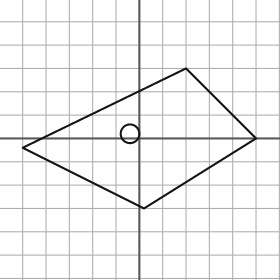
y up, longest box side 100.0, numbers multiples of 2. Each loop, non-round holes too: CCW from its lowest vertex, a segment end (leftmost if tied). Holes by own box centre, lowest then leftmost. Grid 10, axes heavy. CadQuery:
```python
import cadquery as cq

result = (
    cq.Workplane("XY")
    .moveTo(2.0, -30.0)
    .lineTo(50.0, 0.0)
    .lineTo(20.0, 30.0)
    .lineTo(-50.0, -4.0)
    .close()
    .moveTo(-4.0, 2.0)
    .circle(4.0)
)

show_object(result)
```